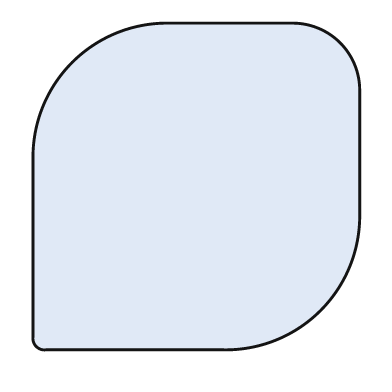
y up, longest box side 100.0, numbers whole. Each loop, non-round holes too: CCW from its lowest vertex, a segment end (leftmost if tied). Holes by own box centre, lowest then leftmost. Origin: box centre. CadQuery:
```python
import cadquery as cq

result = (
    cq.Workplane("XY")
    .moveTo(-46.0, -50.0)
    .lineTo(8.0, -50.0)
    .threePointArc((38.0, -38.0), (50.0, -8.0))
    .lineTo(50.0, 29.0)
    .threePointArc((44.0, 44.0), (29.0, 50.0))
    .lineTo(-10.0, 50.0)
    .threePointArc((-38.0, 38.0), (-50.0, 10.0))
    .lineTo(-50.0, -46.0)
    .threePointArc((-49.0, -49.0), (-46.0, -50.0))
    .close()
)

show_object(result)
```